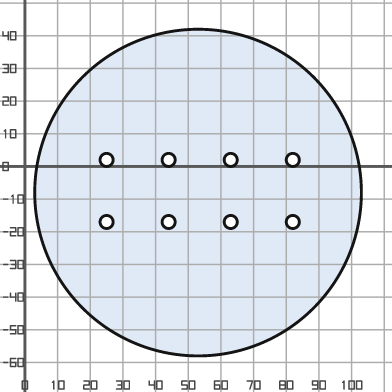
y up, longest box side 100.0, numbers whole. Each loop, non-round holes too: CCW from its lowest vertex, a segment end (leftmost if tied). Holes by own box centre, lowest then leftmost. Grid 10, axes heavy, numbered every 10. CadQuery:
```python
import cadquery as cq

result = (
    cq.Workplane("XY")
    .moveTo(53.0, -8.0)
    .circle(50.0)
    .moveTo(25.0, -17.0)
    .circle(2.0)
    .moveTo(44.0, -17.0)
    .circle(2.0)
    .moveTo(63.0, -17.0)
    .circle(2.0)
    .moveTo(82.0, -17.0)
    .circle(2.0)
    .moveTo(25.0, 2.0)
    .circle(2.0)
    .moveTo(44.0, 2.0)
    .circle(2.0)
    .moveTo(63.0, 2.0)
    .circle(2.0)
    .moveTo(82.0, 2.0)
    .circle(2.0)
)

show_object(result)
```